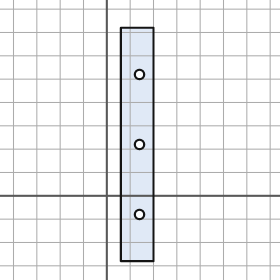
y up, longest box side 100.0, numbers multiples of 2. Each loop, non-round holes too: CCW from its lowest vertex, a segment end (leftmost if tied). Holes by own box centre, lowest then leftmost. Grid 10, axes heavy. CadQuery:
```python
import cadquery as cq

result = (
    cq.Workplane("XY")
    .moveTo(6.0, -28.0)
    .lineTo(20.0, -28.0)
    .lineTo(20.0, 72.0)
    .lineTo(6.0, 72.0)
    .close()
    .moveTo(14.0, -8.0)
    .circle(2.0)
    .moveTo(14.0, 22.0)
    .circle(2.0)
    .moveTo(14.0, 52.0)
    .circle(2.0)
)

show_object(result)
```